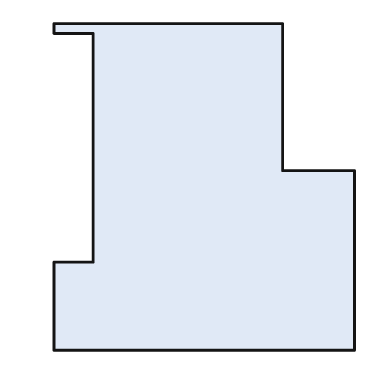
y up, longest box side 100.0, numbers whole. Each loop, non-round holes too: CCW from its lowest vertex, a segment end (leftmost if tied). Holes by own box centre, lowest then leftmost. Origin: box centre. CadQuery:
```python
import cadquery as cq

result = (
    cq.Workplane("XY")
    .moveTo(-46.0, -50.0)
    .lineTo(46.0, -50.0)
    .lineTo(46.0, 5.0)
    .lineTo(24.0, 5.0)
    .lineTo(24.0, 50.0)
    .lineTo(-46.0, 50.0)
    .lineTo(-46.0, 47.0)
    .lineTo(-34.0, 47.0)
    .lineTo(-34.0, -23.0)
    .lineTo(-46.0, -23.0)
    .close()
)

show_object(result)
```